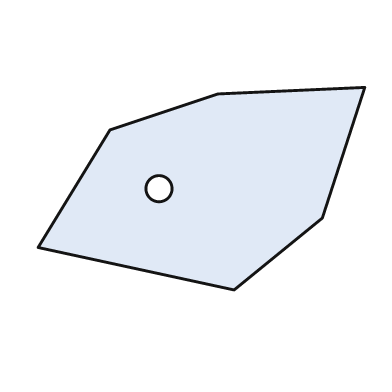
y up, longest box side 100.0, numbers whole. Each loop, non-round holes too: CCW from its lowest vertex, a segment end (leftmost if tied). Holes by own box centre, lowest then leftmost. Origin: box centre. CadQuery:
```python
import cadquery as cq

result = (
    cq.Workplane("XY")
    .moveTo(10.0, -31.0)
    .lineTo(37.0, -9.0)
    .lineTo(50.0, 31.0)
    .lineTo(5.0, 29.0)
    .lineTo(-28.0, 18.0)
    .lineTo(-50.0, -18.0)
    .close()
    .moveTo(-13.0, 0.0)
    .circle(4.0)
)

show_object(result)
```